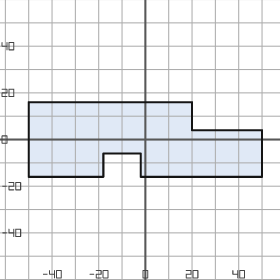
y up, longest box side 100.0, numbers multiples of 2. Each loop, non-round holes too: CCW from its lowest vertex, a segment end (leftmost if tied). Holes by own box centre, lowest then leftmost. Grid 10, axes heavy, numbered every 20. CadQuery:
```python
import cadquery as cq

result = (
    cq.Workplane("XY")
    .moveTo(-50.0, -16.0)
    .lineTo(-18.0, -16.0)
    .lineTo(-18.0, -6.0)
    .lineTo(-2.0, -6.0)
    .lineTo(-2.0, -16.0)
    .lineTo(50.0, -16.0)
    .lineTo(50.0, 4.0)
    .lineTo(20.0, 4.0)
    .lineTo(20.0, 16.0)
    .lineTo(-50.0, 16.0)
    .close()
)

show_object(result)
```